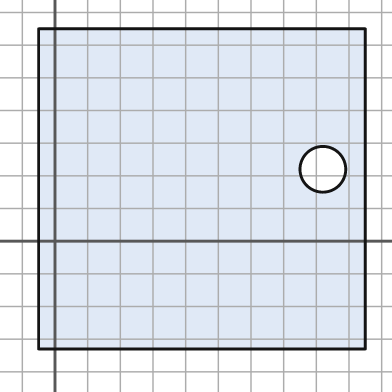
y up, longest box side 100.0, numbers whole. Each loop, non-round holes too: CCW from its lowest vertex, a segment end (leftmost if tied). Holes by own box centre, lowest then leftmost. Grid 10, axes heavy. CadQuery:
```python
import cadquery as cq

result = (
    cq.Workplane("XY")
    .moveTo(-5.0, -33.0)
    .lineTo(95.0, -33.0)
    .lineTo(95.0, 65.0)
    .lineTo(-5.0, 65.0)
    .close()
    .moveTo(82.0, 22.0)
    .circle(7.0)
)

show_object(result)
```